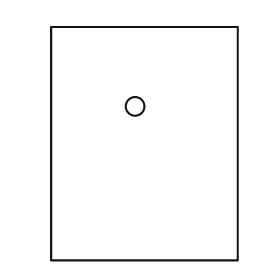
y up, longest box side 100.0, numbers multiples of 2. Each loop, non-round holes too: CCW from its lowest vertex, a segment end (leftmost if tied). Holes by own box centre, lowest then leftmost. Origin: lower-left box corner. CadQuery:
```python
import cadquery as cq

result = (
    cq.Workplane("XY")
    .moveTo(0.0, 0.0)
    .lineTo(80.0, 0.0)
    .lineTo(80.0, 100.0)
    .lineTo(0.0, 100.0)
    .close()
    .moveTo(36.0, 66.0)
    .circle(4.0)
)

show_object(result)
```